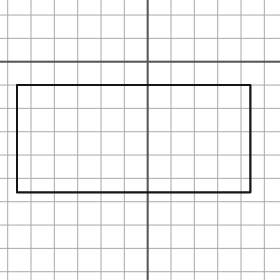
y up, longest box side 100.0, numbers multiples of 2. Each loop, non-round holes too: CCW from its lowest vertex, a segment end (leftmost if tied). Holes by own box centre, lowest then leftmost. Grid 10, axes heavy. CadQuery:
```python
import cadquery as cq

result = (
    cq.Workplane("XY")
    .moveTo(-56.0, -56.0)
    .lineTo(44.0, -56.0)
    .lineTo(44.0, -10.0)
    .lineTo(-56.0, -10.0)
    .close()
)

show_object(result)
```